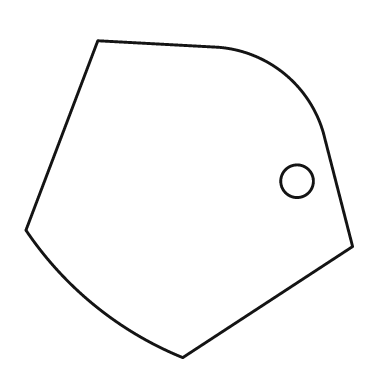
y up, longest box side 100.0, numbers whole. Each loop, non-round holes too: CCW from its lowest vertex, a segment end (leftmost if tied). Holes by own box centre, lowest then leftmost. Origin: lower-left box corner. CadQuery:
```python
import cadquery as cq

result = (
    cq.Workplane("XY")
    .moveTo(48.0, 0.0)
    .lineTo(100.0, 34.0)
    .lineTo(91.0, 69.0)
    .threePointArc((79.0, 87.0), (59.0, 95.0))
    .lineTo(22.0, 97.0)
    .lineTo(0.0, 39.0)
    .threePointArc((21.0, 16.0), (48.0, 0.0))
    .close()
    .moveTo(83.0, 54.0)
    .circle(5.0)
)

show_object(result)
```